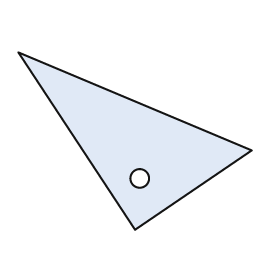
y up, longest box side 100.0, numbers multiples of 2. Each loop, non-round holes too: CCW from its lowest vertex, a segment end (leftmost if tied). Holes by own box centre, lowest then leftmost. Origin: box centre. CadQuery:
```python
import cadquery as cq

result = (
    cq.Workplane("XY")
    .moveTo(0.0, -38.0)
    .lineTo(50.0, -4.0)
    .lineTo(-50.0, 38.0)
    .close()
    .moveTo(2.0, -16.0)
    .circle(4.0)
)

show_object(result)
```